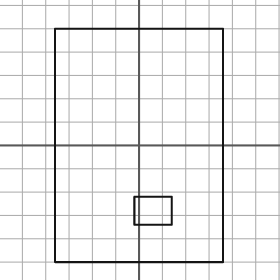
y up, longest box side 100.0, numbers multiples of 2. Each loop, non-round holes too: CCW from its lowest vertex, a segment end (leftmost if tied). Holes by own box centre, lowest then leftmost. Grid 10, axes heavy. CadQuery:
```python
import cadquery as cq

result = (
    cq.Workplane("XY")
    .moveTo(-36.0, -50.0)
    .lineTo(36.0, -50.0)
    .lineTo(36.0, 50.0)
    .lineTo(-36.0, 50.0)
    .close()
    .moveTo(-2.0, -34.0)
    .lineTo(14.0, -34.0)
    .lineTo(14.0, -22.0)
    .lineTo(-2.0, -22.0)
    .close()
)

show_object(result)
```